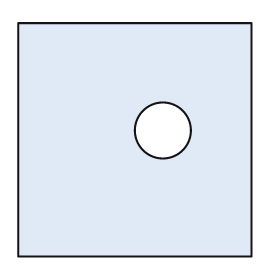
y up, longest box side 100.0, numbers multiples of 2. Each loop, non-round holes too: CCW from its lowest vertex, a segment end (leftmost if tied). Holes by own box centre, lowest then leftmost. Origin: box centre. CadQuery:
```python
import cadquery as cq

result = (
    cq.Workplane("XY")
    .moveTo(-50.0, -50.0)
    .lineTo(50.0, -50.0)
    .lineTo(50.0, 50.0)
    .lineTo(-50.0, 50.0)
    .close()
    .moveTo(12.0, 4.0)
    .circle(12.0)
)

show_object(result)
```